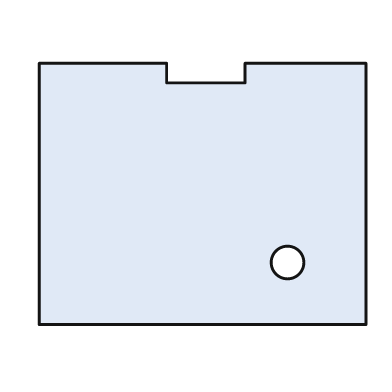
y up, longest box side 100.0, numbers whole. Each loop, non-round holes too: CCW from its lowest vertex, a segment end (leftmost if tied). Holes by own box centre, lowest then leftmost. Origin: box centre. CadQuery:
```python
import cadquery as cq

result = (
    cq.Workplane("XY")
    .moveTo(-50.0, -40.0)
    .lineTo(50.0, -40.0)
    .lineTo(50.0, 40.0)
    .lineTo(13.0, 40.0)
    .lineTo(13.0, 34.0)
    .lineTo(-11.0, 34.0)
    .lineTo(-11.0, 40.0)
    .lineTo(-50.0, 40.0)
    .close()
    .moveTo(26.0, -21.0)
    .circle(5.0)
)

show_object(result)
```